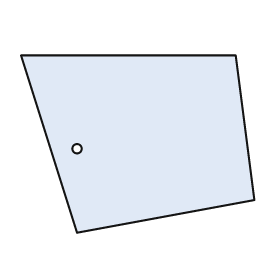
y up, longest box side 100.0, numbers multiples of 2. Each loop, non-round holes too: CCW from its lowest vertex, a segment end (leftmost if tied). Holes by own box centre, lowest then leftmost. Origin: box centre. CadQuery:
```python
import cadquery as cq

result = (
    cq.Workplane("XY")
    .moveTo(-26.0, -38.0)
    .lineTo(50.0, -24.0)
    .lineTo(42.0, 38.0)
    .lineTo(-50.0, 38.0)
    .close()
    .moveTo(-26.0, -2.0)
    .circle(2.0)
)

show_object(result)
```